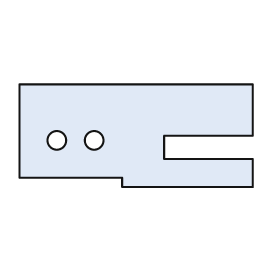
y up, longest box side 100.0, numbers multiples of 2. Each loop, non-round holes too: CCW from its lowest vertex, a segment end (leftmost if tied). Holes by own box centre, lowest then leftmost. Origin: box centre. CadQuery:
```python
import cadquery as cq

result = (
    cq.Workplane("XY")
    .moveTo(-6.0, -22.0)
    .lineTo(50.0, -22.0)
    .lineTo(50.0, -10.0)
    .lineTo(12.0, -10.0)
    .lineTo(12.0, 0.0)
    .lineTo(50.0, 0.0)
    .lineTo(50.0, 22.0)
    .lineTo(-50.0, 22.0)
    .lineTo(-50.0, -18.0)
    .lineTo(-6.0, -18.0)
    .close()
    .moveTo(-34.0, -2.0)
    .circle(4.0)
    .moveTo(-18.0, -2.0)
    .circle(4.0)
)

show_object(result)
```